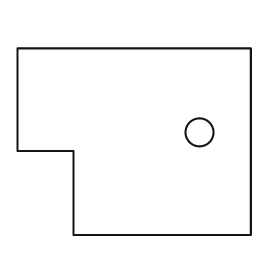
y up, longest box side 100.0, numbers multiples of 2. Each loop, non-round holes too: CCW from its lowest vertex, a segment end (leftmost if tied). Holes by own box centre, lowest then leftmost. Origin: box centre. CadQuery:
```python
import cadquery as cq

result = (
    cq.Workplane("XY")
    .moveTo(-26.0, -40.0)
    .lineTo(50.0, -40.0)
    .lineTo(50.0, 40.0)
    .lineTo(-50.0, 40.0)
    .lineTo(-50.0, -4.0)
    .lineTo(-26.0, -4.0)
    .close()
    .moveTo(28.0, 4.0)
    .circle(6.0)
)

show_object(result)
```